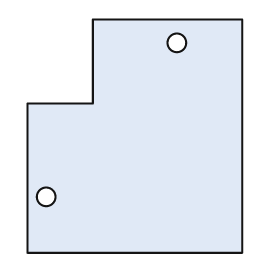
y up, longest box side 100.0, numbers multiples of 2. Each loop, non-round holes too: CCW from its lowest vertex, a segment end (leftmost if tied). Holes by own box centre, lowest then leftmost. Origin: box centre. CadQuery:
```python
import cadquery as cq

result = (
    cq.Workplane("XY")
    .moveTo(-46.0, -50.0)
    .lineTo(46.0, -50.0)
    .lineTo(46.0, 50.0)
    .lineTo(-18.0, 50.0)
    .lineTo(-18.0, 14.0)
    .lineTo(-46.0, 14.0)
    .close()
    .moveTo(-38.0, -26.0)
    .circle(4.0)
    .moveTo(18.0, 40.0)
    .circle(4.0)
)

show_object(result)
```